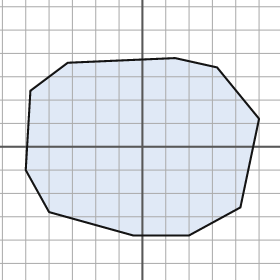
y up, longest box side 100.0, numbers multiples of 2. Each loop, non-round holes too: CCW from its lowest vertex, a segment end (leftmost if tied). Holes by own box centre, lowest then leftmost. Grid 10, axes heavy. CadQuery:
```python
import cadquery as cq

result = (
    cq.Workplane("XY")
    .moveTo(-4.0, -38.0)
    .lineTo(20.0, -38.0)
    .lineTo(42.0, -26.0)
    .lineTo(50.0, 12.0)
    .lineTo(32.0, 34.0)
    .lineTo(14.0, 38.0)
    .lineTo(-32.0, 36.0)
    .lineTo(-48.0, 24.0)
    .lineTo(-50.0, -10.0)
    .lineTo(-40.0, -28.0)
    .close()
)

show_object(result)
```